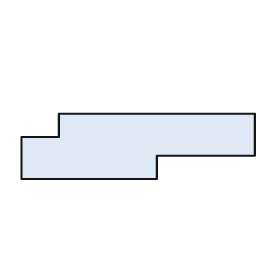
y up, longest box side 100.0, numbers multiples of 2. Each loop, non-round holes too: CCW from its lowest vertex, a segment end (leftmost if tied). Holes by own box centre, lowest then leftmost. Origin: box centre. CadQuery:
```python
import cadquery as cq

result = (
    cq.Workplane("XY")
    .moveTo(-50.0, -14.0)
    .lineTo(8.0, -14.0)
    .lineTo(8.0, -4.0)
    .lineTo(50.0, -4.0)
    .lineTo(50.0, 14.0)
    .lineTo(-34.0, 14.0)
    .lineTo(-34.0, 4.0)
    .lineTo(-50.0, 4.0)
    .close()
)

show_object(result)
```